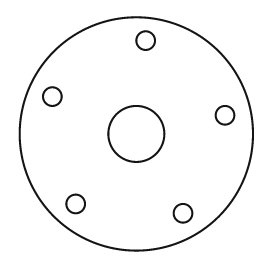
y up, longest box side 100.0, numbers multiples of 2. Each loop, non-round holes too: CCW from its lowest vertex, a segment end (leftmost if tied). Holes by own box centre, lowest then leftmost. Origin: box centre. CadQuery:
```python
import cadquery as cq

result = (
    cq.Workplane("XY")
    .moveTo(0.0, 0.0)
    .circle(50.0)
    .moveTo(20.0, -34.0)
    .circle(4.0)
    .moveTo(-26.0, -30.0)
    .circle(4.0)
    .moveTo(0.0, 0.0)
    .circle(12.0)
    .moveTo(38.0, 8.0)
    .circle(4.0)
    .moveTo(-36.0, 16.0)
    .circle(4.0)
    .moveTo(4.0, 40.0)
    .circle(4.0)
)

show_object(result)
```